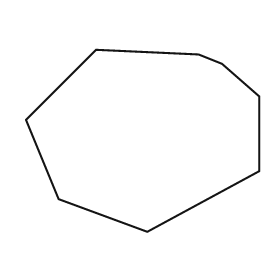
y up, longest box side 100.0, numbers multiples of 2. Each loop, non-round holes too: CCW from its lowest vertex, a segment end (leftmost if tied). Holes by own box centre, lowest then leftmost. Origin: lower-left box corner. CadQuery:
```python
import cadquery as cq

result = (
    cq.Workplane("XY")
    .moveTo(52.0, 0.0)
    .lineTo(100.0, 26.0)
    .lineTo(100.0, 58.0)
    .lineTo(84.0, 72.0)
    .lineTo(74.0, 76.0)
    .lineTo(30.0, 78.0)
    .lineTo(0.0, 48.0)
    .lineTo(14.0, 14.0)
    .close()
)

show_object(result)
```